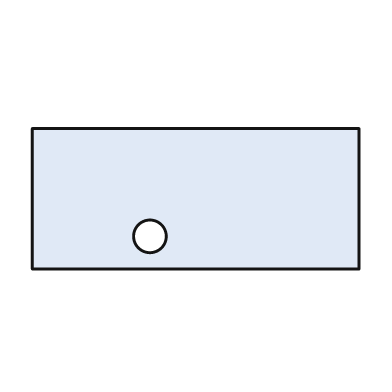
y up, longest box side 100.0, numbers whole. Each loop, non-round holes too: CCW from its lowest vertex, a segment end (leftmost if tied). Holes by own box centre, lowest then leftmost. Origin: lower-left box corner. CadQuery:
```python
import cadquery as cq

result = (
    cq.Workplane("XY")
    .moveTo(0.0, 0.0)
    .lineTo(100.0, 0.0)
    .lineTo(100.0, 43.0)
    .lineTo(0.0, 43.0)
    .close()
    .moveTo(36.0, 10.0)
    .circle(5.0)
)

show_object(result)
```